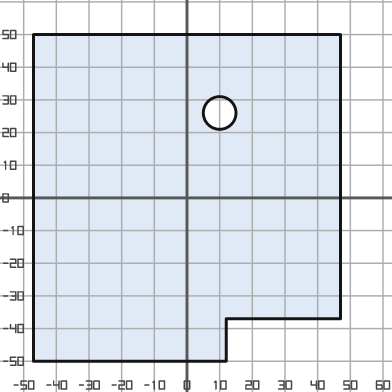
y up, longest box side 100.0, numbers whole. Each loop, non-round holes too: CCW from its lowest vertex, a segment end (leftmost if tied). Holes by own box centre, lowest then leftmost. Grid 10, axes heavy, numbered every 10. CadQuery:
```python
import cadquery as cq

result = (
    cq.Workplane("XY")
    .moveTo(-47.0, -50.0)
    .lineTo(12.0, -50.0)
    .lineTo(12.0, -37.0)
    .lineTo(47.0, -37.0)
    .lineTo(47.0, 50.0)
    .lineTo(-47.0, 50.0)
    .close()
    .moveTo(10.0, 26.0)
    .circle(5.0)
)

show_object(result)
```